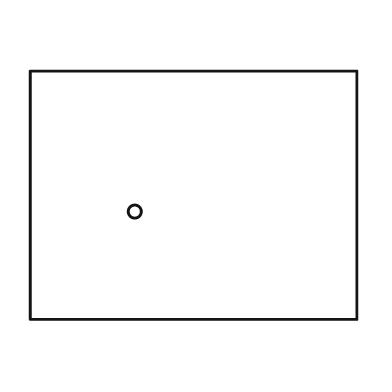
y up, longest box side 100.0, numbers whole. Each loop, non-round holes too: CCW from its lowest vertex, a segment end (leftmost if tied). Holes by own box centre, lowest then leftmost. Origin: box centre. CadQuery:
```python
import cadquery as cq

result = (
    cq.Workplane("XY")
    .moveTo(-50.0, -38.0)
    .lineTo(50.0, -38.0)
    .lineTo(50.0, 38.0)
    .lineTo(-50.0, 38.0)
    .close()
    .moveTo(-18.0, -5.0)
    .circle(2.0)
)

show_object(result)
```